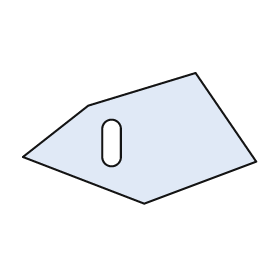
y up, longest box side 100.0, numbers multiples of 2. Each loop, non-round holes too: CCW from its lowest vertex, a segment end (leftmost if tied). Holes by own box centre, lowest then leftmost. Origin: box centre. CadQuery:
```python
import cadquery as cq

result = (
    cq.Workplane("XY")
    .moveTo(2.0, -28.0)
    .lineTo(50.0, -10.0)
    .lineTo(24.0, 28.0)
    .lineTo(-22.0, 14.0)
    .lineTo(-50.0, -8.0)
    .close()
    .moveTo(-16.0, -8.0)
    .threePointArc((-12.0, -12.0), (-8.0, -8.0))
    .lineTo(-8.0, 4.0)
    .threePointArc((-12.0, 8.0), (-16.0, 4.0))
    .close()
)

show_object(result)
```